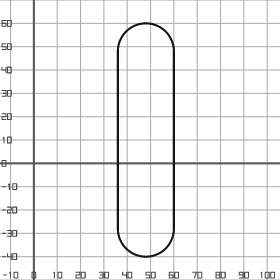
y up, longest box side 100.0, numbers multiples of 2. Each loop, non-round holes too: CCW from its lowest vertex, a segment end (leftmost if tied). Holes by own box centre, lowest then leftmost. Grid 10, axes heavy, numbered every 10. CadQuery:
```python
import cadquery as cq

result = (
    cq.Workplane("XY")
    .moveTo(36.0, -28.0)
    .threePointArc((48.0, -40.0), (60.0, -28.0))
    .lineTo(60.0, 48.0)
    .threePointArc((48.0, 60.0), (36.0, 48.0))
    .close()
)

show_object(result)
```